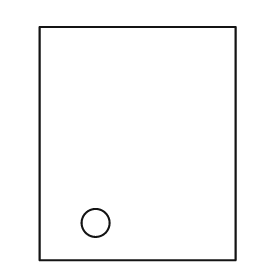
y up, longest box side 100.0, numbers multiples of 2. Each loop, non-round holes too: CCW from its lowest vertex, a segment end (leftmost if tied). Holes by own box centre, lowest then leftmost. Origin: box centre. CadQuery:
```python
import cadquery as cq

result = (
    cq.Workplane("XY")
    .moveTo(-42.0, -50.0)
    .lineTo(42.0, -50.0)
    .lineTo(42.0, 50.0)
    .lineTo(-42.0, 50.0)
    .close()
    .moveTo(-18.0, -34.0)
    .circle(6.0)
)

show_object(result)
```